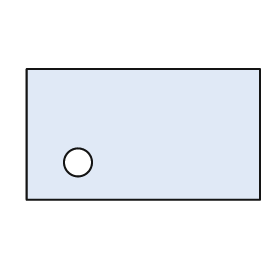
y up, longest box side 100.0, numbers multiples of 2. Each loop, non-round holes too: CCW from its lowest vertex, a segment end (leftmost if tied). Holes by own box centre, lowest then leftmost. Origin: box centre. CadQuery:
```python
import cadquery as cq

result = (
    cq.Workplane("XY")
    .moveTo(-50.0, -28.0)
    .lineTo(50.0, -28.0)
    .lineTo(50.0, 28.0)
    .lineTo(-50.0, 28.0)
    .close()
    .moveTo(-28.0, -12.0)
    .circle(6.0)
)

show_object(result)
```